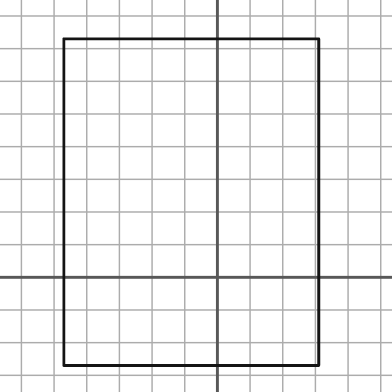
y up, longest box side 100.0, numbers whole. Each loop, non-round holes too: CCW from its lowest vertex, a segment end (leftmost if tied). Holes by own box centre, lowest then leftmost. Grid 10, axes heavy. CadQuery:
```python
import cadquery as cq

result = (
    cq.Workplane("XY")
    .moveTo(-47.0, -27.0)
    .lineTo(31.0, -27.0)
    .lineTo(31.0, 73.0)
    .lineTo(-47.0, 73.0)
    .close()
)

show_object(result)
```